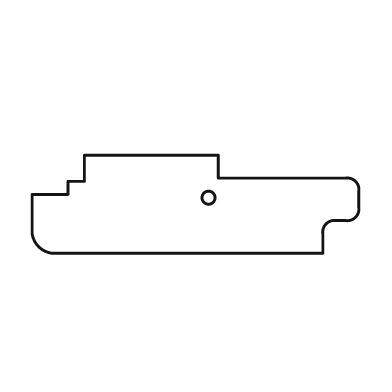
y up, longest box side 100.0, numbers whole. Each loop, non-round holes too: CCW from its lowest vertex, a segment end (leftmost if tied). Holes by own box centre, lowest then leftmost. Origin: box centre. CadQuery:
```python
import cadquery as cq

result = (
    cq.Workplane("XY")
    .moveTo(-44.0, -15.0)
    .lineTo(39.0, -15.0)
    .lineTo(39.0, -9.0)
    .threePointArc((40.0, -6.0), (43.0, -5.0))
    .lineTo(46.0, -5.0)
    .threePointArc((49.0, -4.0), (50.0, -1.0))
    .lineTo(50.0, 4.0)
    .threePointArc((49.0, 7.0), (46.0, 8.0))
    .lineTo(7.0, 8.0)
    .lineTo(7.0, 15.0)
    .lineTo(-34.0, 15.0)
    .lineTo(-34.0, 7.0)
    .lineTo(-39.0, 7.0)
    .lineTo(-39.0, 3.0)
    .lineTo(-50.0, 3.0)
    .lineTo(-50.0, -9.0)
    .threePointArc((-48.0, -13.0), (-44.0, -15.0))
    .close()
    .moveTo(4.0, 2.0)
    .circle(2.0)
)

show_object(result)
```